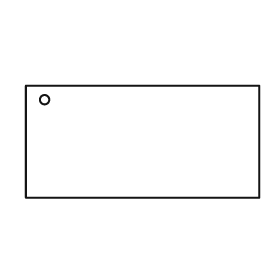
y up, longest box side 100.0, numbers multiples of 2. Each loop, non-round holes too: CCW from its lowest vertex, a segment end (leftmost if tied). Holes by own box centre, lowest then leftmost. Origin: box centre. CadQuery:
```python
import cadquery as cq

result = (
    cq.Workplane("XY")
    .moveTo(-50.0, -24.0)
    .lineTo(50.0, -24.0)
    .lineTo(50.0, 24.0)
    .lineTo(-50.0, 24.0)
    .close()
    .moveTo(-42.0, 18.0)
    .circle(2.0)
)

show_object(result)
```